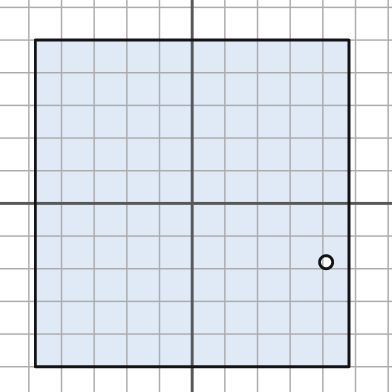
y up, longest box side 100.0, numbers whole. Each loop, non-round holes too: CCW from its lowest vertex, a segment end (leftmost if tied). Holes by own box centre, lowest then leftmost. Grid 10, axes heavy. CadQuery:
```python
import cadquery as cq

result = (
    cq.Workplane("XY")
    .moveTo(-48.0, -50.0)
    .lineTo(48.0, -50.0)
    .lineTo(48.0, 50.0)
    .lineTo(-48.0, 50.0)
    .close()
    .moveTo(41.0, -18.0)
    .circle(2.0)
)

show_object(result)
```